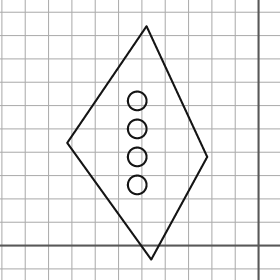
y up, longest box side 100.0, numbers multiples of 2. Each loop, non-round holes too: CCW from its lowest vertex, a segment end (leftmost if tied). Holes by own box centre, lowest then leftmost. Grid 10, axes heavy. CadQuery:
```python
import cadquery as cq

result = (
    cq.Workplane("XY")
    .moveTo(-46.0, -6.0)
    .lineTo(-22.0, 38.0)
    .lineTo(-48.0, 94.0)
    .lineTo(-82.0, 44.0)
    .close()
    .moveTo(-52.0, 26.0)
    .circle(4.0)
    .moveTo(-52.0, 38.0)
    .circle(4.0)
    .moveTo(-52.0, 50.0)
    .circle(4.0)
    .moveTo(-52.0, 62.0)
    .circle(4.0)
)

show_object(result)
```